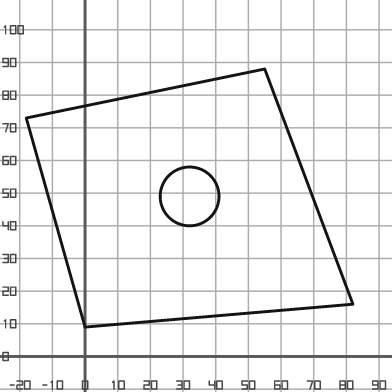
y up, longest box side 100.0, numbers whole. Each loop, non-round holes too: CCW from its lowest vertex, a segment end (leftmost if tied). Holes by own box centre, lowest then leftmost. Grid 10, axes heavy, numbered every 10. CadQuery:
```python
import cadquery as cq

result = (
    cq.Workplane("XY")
    .moveTo(0.0, 9.0)
    .lineTo(82.0, 16.0)
    .lineTo(55.0, 88.0)
    .lineTo(-18.0, 73.0)
    .close()
    .moveTo(32.0, 49.0)
    .circle(9.0)
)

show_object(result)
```